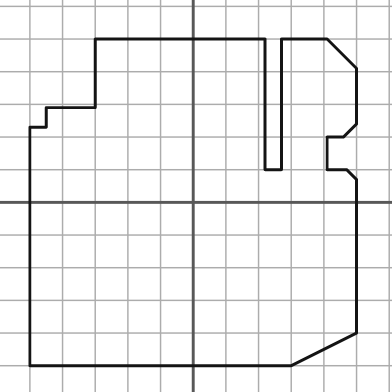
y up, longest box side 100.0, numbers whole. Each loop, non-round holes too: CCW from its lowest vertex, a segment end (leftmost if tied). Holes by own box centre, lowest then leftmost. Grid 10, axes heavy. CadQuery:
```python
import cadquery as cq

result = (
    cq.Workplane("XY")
    .moveTo(-50.0, -50.0)
    .lineTo(30.0, -50.0)
    .lineTo(50.0, -40.0)
    .lineTo(50.0, 7.0)
    .lineTo(47.0, 10.0)
    .lineTo(41.0, 10.0)
    .lineTo(41.0, 20.0)
    .lineTo(46.0, 20.0)
    .lineTo(50.0, 24.0)
    .lineTo(50.0, 41.0)
    .lineTo(41.0, 50.0)
    .lineTo(27.0, 50.0)
    .lineTo(27.0, 10.0)
    .lineTo(22.0, 10.0)
    .lineTo(22.0, 50.0)
    .lineTo(-30.0, 50.0)
    .lineTo(-30.0, 29.0)
    .lineTo(-45.0, 29.0)
    .lineTo(-45.0, 23.0)
    .lineTo(-50.0, 23.0)
    .close()
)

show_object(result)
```